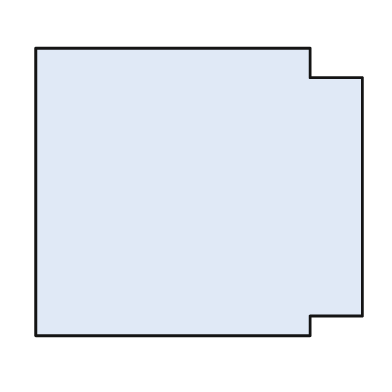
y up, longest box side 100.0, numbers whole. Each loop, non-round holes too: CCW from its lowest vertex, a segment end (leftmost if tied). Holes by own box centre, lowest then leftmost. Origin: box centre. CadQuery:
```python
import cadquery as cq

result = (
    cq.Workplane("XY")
    .moveTo(-50.0, -44.0)
    .lineTo(34.0, -44.0)
    .lineTo(34.0, -38.0)
    .lineTo(50.0, -38.0)
    .lineTo(50.0, 35.0)
    .lineTo(34.0, 35.0)
    .lineTo(34.0, 44.0)
    .lineTo(-50.0, 44.0)
    .close()
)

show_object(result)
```